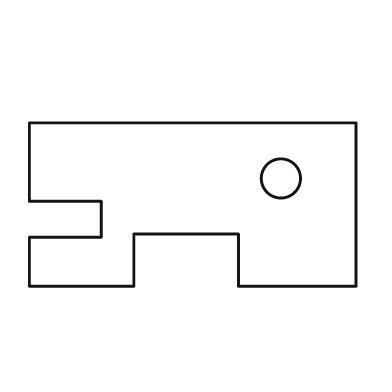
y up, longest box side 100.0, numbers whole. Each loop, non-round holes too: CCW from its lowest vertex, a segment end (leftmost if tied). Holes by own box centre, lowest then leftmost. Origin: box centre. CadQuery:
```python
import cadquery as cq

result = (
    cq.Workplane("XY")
    .moveTo(-50.0, -25.0)
    .lineTo(-18.0, -25.0)
    .lineTo(-18.0, -9.0)
    .lineTo(14.0, -9.0)
    .lineTo(14.0, -25.0)
    .lineTo(50.0, -25.0)
    .lineTo(50.0, 25.0)
    .lineTo(-50.0, 25.0)
    .lineTo(-50.0, 1.0)
    .lineTo(-28.0, 1.0)
    .lineTo(-28.0, -10.0)
    .lineTo(-50.0, -10.0)
    .close()
    .moveTo(27.0, 8.0)
    .circle(6.0)
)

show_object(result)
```